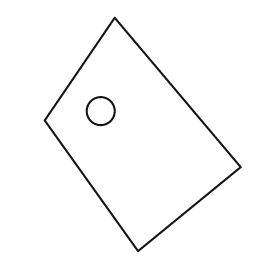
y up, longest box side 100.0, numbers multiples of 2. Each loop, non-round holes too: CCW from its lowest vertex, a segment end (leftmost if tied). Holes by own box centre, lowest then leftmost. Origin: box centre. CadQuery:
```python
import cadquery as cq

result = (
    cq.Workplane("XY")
    .moveTo(-2.0, -50.0)
    .lineTo(42.0, -14.0)
    .lineTo(-12.0, 50.0)
    .lineTo(-42.0, 6.0)
    .close()
    .moveTo(-18.0, 10.0)
    .circle(6.0)
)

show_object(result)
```